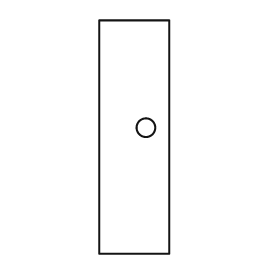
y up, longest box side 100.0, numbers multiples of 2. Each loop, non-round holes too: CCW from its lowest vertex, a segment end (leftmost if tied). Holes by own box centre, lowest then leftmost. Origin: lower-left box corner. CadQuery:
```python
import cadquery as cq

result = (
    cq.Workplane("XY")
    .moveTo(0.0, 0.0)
    .lineTo(30.0, 0.0)
    .lineTo(30.0, 100.0)
    .lineTo(0.0, 100.0)
    .close()
    .moveTo(20.0, 54.0)
    .circle(4.0)
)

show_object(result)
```